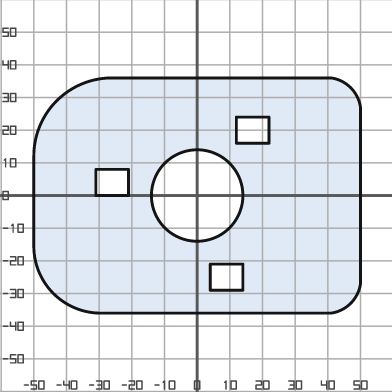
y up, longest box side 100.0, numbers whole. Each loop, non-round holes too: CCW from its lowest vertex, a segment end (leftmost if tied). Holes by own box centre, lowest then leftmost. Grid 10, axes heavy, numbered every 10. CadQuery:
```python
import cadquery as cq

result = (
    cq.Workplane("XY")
    .moveTo(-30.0, -36.0)
    .lineTo(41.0, -36.0)
    .threePointArc((47.0, -33.0), (50.0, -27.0))
    .lineTo(50.0, 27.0)
    .threePointArc((47.0, 33.0), (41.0, 36.0))
    .lineTo(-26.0, 36.0)
    .threePointArc((-43.0, 29.0), (-50.0, 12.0))
    .lineTo(-50.0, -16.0)
    .threePointArc((-44.0, -30.0), (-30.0, -36.0))
    .close()
    .moveTo(4.0, -29.0)
    .lineTo(14.0, -29.0)
    .lineTo(14.0, -21.0)
    .lineTo(4.0, -21.0)
    .close()
    .moveTo(0.0, 0.0)
    .circle(14.0)
    .moveTo(-31.0, 0.0)
    .lineTo(-21.0, 0.0)
    .lineTo(-21.0, 8.0)
    .lineTo(-31.0, 8.0)
    .close()
    .moveTo(12.0, 16.0)
    .lineTo(22.0, 16.0)
    .lineTo(22.0, 24.0)
    .lineTo(12.0, 24.0)
    .close()
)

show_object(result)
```